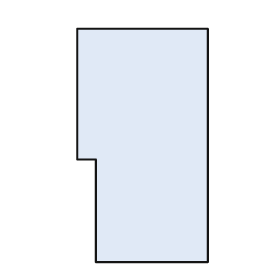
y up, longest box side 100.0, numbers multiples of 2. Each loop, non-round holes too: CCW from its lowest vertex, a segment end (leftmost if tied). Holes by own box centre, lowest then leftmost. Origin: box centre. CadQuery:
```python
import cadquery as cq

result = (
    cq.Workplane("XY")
    .moveTo(-20.0, -50.0)
    .lineTo(28.0, -50.0)
    .lineTo(28.0, 50.0)
    .lineTo(-28.0, 50.0)
    .lineTo(-28.0, -6.0)
    .lineTo(-20.0, -6.0)
    .close()
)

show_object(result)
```